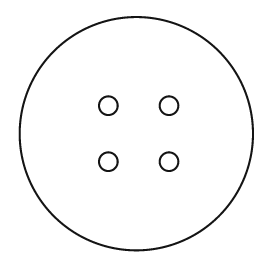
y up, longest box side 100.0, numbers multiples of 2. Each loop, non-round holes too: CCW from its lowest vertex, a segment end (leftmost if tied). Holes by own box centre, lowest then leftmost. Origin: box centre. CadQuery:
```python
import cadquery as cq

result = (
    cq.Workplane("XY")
    .moveTo(0.0, 0.0)
    .circle(50.0)
    .moveTo(-12.0, -12.0)
    .circle(4.0)
    .moveTo(14.0, -12.0)
    .circle(4.0)
    .moveTo(-12.0, 12.0)
    .circle(4.0)
    .moveTo(14.0, 12.0)
    .circle(4.0)
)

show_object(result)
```